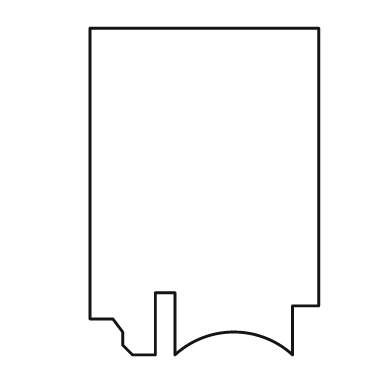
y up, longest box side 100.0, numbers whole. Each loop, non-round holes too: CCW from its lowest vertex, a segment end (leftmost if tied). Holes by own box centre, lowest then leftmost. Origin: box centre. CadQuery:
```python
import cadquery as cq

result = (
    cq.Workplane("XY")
    .moveTo(-22.0, -50.0)
    .lineTo(-15.0, -50.0)
    .lineTo(-15.0, -31.0)
    .lineTo(-9.0, -31.0)
    .lineTo(-9.0, -50.0)
    .threePointArc((9.0, -43.0), (27.0, -50.0))
    .lineTo(27.0, -35.0)
    .lineTo(35.0, -35.0)
    .lineTo(35.0, 50.0)
    .lineTo(-35.0, 50.0)
    .lineTo(-35.0, -39.0)
    .lineTo(-28.0, -39.0)
    .lineTo(-25.0, -43.0)
    .lineTo(-25.0, -47.0)
    .close()
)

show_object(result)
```